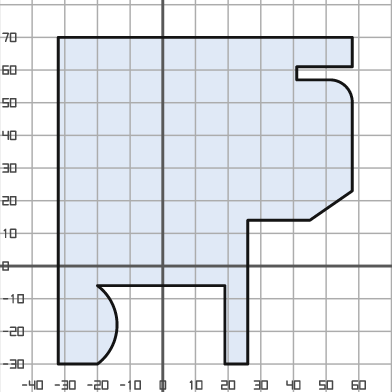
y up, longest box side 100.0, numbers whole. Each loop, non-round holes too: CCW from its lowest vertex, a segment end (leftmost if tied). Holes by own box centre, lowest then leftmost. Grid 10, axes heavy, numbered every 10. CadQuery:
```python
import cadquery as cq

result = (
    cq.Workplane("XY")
    .moveTo(-32.0, -30.0)
    .lineTo(-20.0, -30.0)
    .threePointArc((-14.0, -18.0), (-20.0, -6.0))
    .lineTo(19.0, -6.0)
    .lineTo(19.0, -30.0)
    .lineTo(26.0, -30.0)
    .lineTo(26.0, 14.0)
    .lineTo(45.0, 14.0)
    .lineTo(58.0, 23.0)
    .lineTo(58.0, 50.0)
    .threePointArc((56.0, 55.0), (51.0, 57.0))
    .lineTo(41.0, 57.0)
    .lineTo(41.0, 61.0)
    .lineTo(58.0, 61.0)
    .lineTo(58.0, 70.0)
    .lineTo(-32.0, 70.0)
    .close()
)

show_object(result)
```